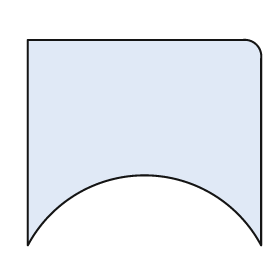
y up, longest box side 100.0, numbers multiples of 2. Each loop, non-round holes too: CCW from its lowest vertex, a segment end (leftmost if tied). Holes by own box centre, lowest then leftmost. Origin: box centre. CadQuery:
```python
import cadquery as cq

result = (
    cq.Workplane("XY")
    .moveTo(-50.0, -44.0)
    .threePointArc((0.0, -14.0), (50.0, -44.0))
    .lineTo(50.0, 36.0)
    .threePointArc((48.0, 42.0), (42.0, 44.0))
    .lineTo(-50.0, 44.0)
    .close()
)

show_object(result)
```